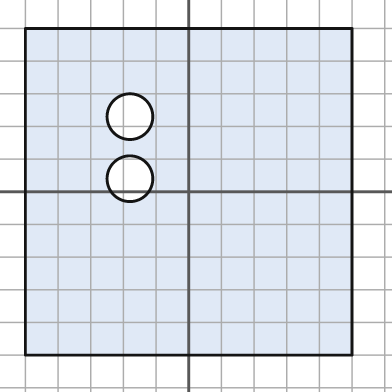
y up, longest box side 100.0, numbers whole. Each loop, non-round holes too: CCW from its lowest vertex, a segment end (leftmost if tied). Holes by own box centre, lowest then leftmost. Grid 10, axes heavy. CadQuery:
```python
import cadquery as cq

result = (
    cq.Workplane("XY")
    .moveTo(-50.0, -50.0)
    .lineTo(50.0, -50.0)
    .lineTo(50.0, 50.0)
    .lineTo(-50.0, 50.0)
    .close()
    .moveTo(-18.0, 4.0)
    .circle(7.0)
    .moveTo(-18.0, 23.0)
    .circle(7.0)
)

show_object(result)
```